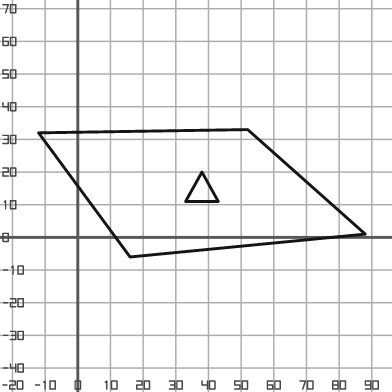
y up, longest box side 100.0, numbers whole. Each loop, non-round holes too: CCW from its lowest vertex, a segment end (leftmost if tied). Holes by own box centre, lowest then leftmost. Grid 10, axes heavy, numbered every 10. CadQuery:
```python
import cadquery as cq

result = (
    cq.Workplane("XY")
    .moveTo(16.0, -6.0)
    .lineTo(88.0, 1.0)
    .lineTo(52.0, 33.0)
    .lineTo(-12.0, 32.0)
    .close()
    .moveTo(33.0, 11.0)
    .lineTo(43.0, 11.0)
    .lineTo(38.0, 20.0)
    .close()
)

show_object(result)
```